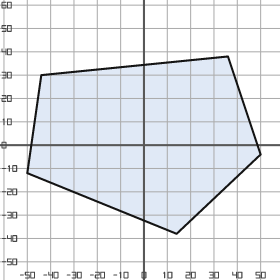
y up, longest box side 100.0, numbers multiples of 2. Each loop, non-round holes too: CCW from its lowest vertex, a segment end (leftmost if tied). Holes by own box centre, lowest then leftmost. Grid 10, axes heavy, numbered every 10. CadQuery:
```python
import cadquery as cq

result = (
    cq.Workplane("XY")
    .moveTo(14.0, -38.0)
    .lineTo(50.0, -4.0)
    .lineTo(36.0, 38.0)
    .lineTo(-44.0, 30.0)
    .lineTo(-50.0, -12.0)
    .close()
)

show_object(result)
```